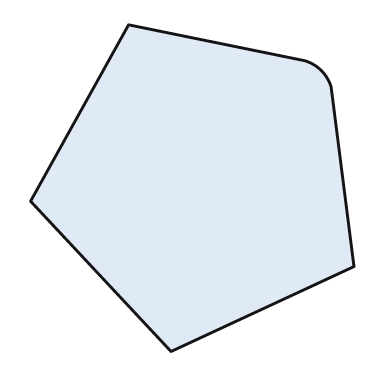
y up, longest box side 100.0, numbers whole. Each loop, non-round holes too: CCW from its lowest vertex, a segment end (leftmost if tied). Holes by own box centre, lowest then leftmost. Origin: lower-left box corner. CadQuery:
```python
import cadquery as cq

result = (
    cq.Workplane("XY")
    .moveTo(43.0, 0.0)
    .lineTo(99.0, 26.0)
    .lineTo(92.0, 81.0)
    .threePointArc((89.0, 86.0), (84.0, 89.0))
    .lineTo(30.0, 100.0)
    .lineTo(0.0, 46.0)
    .close()
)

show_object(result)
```